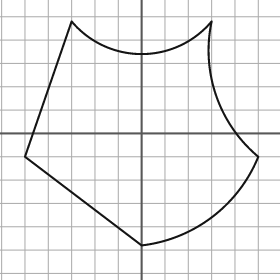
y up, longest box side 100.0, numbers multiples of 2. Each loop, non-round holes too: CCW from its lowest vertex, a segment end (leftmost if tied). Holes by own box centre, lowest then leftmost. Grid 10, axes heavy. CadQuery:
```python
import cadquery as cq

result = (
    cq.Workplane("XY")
    .moveTo(0.0, -48.0)
    .threePointArc((30.0, -36.0), (50.0, -10.0))
    .threePointArc((32.0, 16.0), (30.0, 48.0))
    .threePointArc((0.0, 34.0), (-30.0, 48.0))
    .lineTo(-50.0, -10.0)
    .close()
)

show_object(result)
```